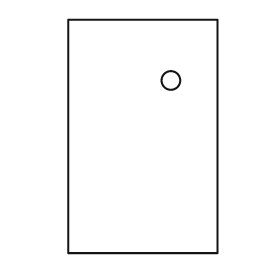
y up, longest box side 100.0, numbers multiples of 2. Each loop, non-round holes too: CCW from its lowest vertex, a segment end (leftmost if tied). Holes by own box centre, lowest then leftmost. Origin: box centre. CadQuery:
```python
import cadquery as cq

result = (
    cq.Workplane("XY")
    .moveTo(-32.0, -50.0)
    .lineTo(32.0, -50.0)
    .lineTo(32.0, 50.0)
    .lineTo(-32.0, 50.0)
    .close()
    .moveTo(12.0, 24.0)
    .circle(4.0)
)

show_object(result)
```